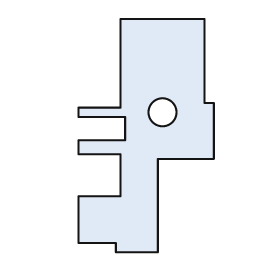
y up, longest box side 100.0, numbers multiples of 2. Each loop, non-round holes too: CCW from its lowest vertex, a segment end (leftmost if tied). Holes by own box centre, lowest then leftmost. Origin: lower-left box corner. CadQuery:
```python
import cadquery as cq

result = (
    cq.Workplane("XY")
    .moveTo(16.0, 0.0)
    .lineTo(34.0, 0.0)
    .lineTo(34.0, 40.0)
    .lineTo(58.0, 40.0)
    .lineTo(58.0, 64.0)
    .lineTo(54.0, 64.0)
    .lineTo(54.0, 100.0)
    .lineTo(18.0, 100.0)
    .lineTo(18.0, 62.0)
    .lineTo(0.0, 62.0)
    .lineTo(0.0, 58.0)
    .lineTo(20.0, 58.0)
    .lineTo(20.0, 48.0)
    .lineTo(0.0, 48.0)
    .lineTo(0.0, 42.0)
    .lineTo(18.0, 42.0)
    .lineTo(18.0, 24.0)
    .lineTo(0.0, 24.0)
    .lineTo(0.0, 4.0)
    .lineTo(16.0, 4.0)
    .close()
    .moveTo(36.0, 60.0)
    .circle(6.0)
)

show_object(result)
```